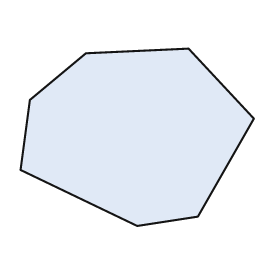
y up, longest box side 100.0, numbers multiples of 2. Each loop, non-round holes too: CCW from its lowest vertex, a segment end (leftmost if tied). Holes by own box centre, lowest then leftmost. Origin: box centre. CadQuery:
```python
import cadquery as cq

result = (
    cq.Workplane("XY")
    .moveTo(0.0, -38.0)
    .lineTo(26.0, -34.0)
    .lineTo(50.0, 8.0)
    .lineTo(22.0, 38.0)
    .lineTo(-22.0, 36.0)
    .lineTo(-46.0, 16.0)
    .lineTo(-50.0, -14.0)
    .close()
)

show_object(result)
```